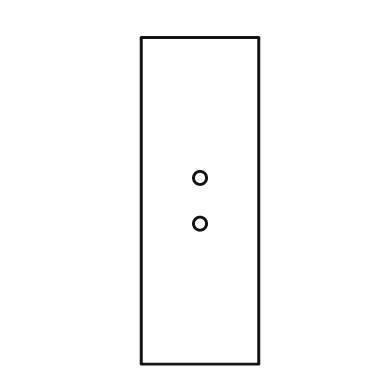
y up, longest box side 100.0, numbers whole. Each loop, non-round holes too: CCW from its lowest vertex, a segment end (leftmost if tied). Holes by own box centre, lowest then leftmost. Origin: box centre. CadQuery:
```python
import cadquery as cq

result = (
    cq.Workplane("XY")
    .moveTo(-18.0, -50.0)
    .lineTo(18.0, -50.0)
    .lineTo(18.0, 50.0)
    .lineTo(-18.0, 50.0)
    .close()
    .moveTo(0.0, -7.0)
    .circle(2.0)
    .moveTo(0.0, 7.0)
    .circle(2.0)
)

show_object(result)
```